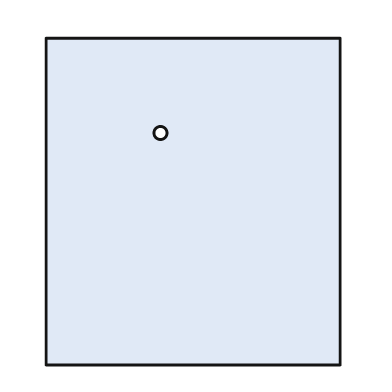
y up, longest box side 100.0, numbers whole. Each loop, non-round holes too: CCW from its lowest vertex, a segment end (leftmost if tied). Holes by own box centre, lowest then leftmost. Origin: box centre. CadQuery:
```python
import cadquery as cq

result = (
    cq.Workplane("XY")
    .moveTo(-45.0, -50.0)
    .lineTo(45.0, -50.0)
    .lineTo(45.0, 50.0)
    .lineTo(-45.0, 50.0)
    .close()
    .moveTo(-10.0, 21.0)
    .circle(2.0)
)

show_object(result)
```